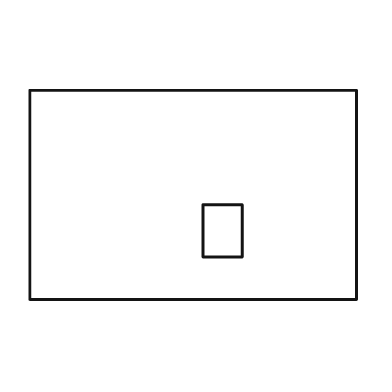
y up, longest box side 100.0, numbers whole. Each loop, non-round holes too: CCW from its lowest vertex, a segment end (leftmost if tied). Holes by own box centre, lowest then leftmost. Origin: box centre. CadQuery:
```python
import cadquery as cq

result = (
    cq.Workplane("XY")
    .moveTo(-50.0, -32.0)
    .lineTo(50.0, -32.0)
    .lineTo(50.0, 32.0)
    .lineTo(-50.0, 32.0)
    .close()
    .moveTo(3.0, -19.0)
    .lineTo(15.0, -19.0)
    .lineTo(15.0, -3.0)
    .lineTo(3.0, -3.0)
    .close()
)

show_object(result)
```